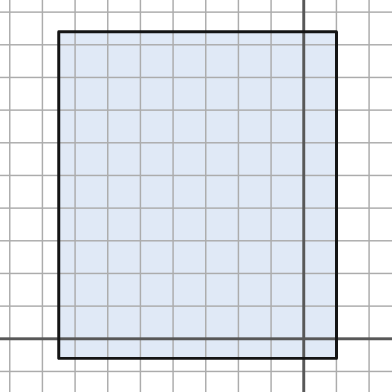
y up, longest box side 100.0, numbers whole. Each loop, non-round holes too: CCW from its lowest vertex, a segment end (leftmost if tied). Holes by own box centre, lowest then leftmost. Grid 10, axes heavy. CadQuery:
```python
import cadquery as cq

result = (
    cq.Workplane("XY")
    .moveTo(-75.0, -6.0)
    .lineTo(10.0, -6.0)
    .lineTo(10.0, 94.0)
    .lineTo(-75.0, 94.0)
    .close()
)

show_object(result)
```